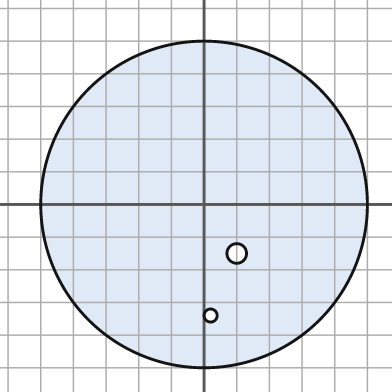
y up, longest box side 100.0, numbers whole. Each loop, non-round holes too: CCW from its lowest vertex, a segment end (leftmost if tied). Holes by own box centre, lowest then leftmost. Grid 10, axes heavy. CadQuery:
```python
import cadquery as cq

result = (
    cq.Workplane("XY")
    .moveTo(0.0, 0.0)
    .circle(50.0)
    .moveTo(2.0, -34.0)
    .circle(2.0)
    .moveTo(10.0, -15.0)
    .circle(3.0)
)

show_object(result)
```